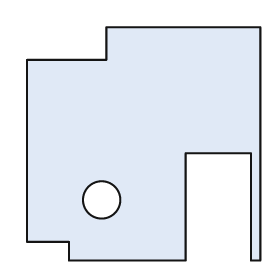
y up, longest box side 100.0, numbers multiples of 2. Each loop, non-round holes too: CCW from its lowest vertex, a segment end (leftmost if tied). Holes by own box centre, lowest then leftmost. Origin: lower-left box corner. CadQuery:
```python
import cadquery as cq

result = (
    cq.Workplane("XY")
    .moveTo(18.0, 0.0)
    .lineTo(68.0, 0.0)
    .lineTo(68.0, 46.0)
    .lineTo(96.0, 46.0)
    .lineTo(96.0, 0.0)
    .lineTo(100.0, 0.0)
    .lineTo(100.0, 100.0)
    .lineTo(34.0, 100.0)
    .lineTo(34.0, 86.0)
    .lineTo(0.0, 86.0)
    .lineTo(0.0, 8.0)
    .lineTo(18.0, 8.0)
    .close()
    .moveTo(32.0, 26.0)
    .circle(8.0)
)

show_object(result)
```